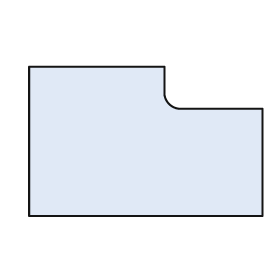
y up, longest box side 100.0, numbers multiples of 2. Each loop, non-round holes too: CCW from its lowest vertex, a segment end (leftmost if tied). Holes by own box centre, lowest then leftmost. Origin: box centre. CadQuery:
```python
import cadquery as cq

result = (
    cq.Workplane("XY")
    .moveTo(-50.0, -32.0)
    .lineTo(50.0, -32.0)
    .lineTo(50.0, 14.0)
    .lineTo(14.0, 14.0)
    .threePointArc((10.0, 16.0), (8.0, 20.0))
    .lineTo(8.0, 32.0)
    .lineTo(-50.0, 32.0)
    .close()
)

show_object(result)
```